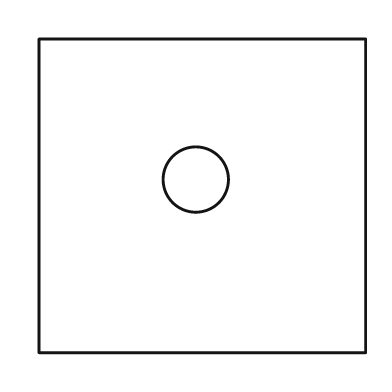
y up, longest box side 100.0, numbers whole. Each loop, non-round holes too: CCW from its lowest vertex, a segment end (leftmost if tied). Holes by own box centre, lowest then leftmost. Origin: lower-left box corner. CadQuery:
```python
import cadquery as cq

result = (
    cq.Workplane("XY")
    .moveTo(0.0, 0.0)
    .lineTo(100.0, 0.0)
    .lineTo(100.0, 96.0)
    .lineTo(0.0, 96.0)
    .close()
    .moveTo(48.0, 53.0)
    .circle(10.0)
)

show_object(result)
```